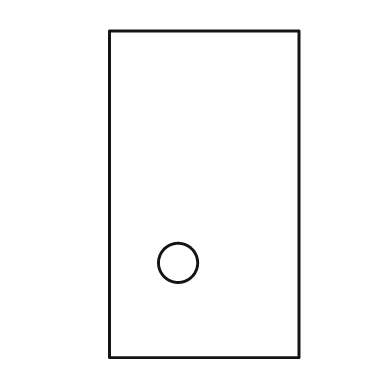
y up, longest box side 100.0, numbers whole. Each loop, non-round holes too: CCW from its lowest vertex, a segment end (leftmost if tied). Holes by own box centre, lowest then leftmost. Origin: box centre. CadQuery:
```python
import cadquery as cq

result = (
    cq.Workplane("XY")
    .moveTo(-29.0, -50.0)
    .lineTo(29.0, -50.0)
    .lineTo(29.0, 50.0)
    .lineTo(-29.0, 50.0)
    .close()
    .moveTo(-8.0, -21.0)
    .circle(6.0)
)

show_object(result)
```